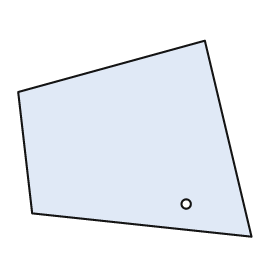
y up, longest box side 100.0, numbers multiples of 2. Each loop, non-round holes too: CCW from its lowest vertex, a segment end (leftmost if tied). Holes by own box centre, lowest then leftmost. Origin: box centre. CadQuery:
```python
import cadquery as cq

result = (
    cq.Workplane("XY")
    .moveTo(50.0, -42.0)
    .lineTo(30.0, 42.0)
    .lineTo(-50.0, 20.0)
    .lineTo(-44.0, -32.0)
    .close()
    .moveTo(22.0, -28.0)
    .circle(2.0)
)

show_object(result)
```